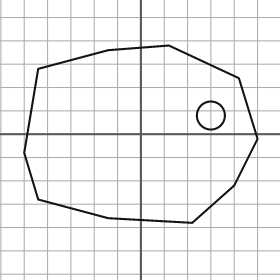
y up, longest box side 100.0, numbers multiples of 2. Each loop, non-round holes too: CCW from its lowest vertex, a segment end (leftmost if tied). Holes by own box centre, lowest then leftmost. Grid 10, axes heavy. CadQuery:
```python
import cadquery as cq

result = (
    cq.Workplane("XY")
    .moveTo(22.0, -38.0)
    .lineTo(40.0, -22.0)
    .lineTo(50.0, -2.0)
    .lineTo(42.0, 24.0)
    .lineTo(12.0, 38.0)
    .lineTo(-14.0, 36.0)
    .lineTo(-44.0, 28.0)
    .lineTo(-50.0, -8.0)
    .lineTo(-44.0, -28.0)
    .lineTo(-14.0, -36.0)
    .close()
    .moveTo(30.0, 8.0)
    .circle(6.0)
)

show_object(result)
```